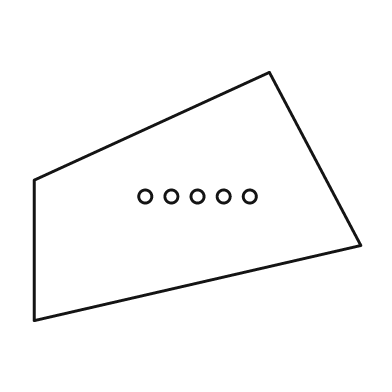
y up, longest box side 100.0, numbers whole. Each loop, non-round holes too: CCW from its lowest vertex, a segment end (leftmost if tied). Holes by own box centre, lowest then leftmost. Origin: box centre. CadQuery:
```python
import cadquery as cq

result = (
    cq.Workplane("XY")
    .moveTo(-50.0, -38.0)
    .lineTo(50.0, -15.0)
    .lineTo(22.0, 38.0)
    .lineTo(-50.0, 5.0)
    .close()
    .moveTo(-16.0, 0.0)
    .circle(2.0)
    .moveTo(-8.0, 0.0)
    .circle(2.0)
    .moveTo(0.0, 0.0)
    .circle(2.0)
    .moveTo(8.0, 0.0)
    .circle(2.0)
    .moveTo(16.0, 0.0)
    .circle(2.0)
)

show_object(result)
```